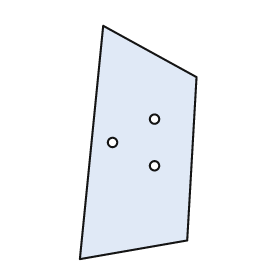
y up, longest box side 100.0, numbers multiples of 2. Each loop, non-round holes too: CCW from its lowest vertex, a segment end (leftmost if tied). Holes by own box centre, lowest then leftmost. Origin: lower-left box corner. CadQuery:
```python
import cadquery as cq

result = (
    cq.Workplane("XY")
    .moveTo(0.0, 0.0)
    .lineTo(46.0, 8.0)
    .lineTo(50.0, 78.0)
    .lineTo(10.0, 100.0)
    .close()
    .moveTo(32.0, 40.0)
    .circle(2.0)
    .moveTo(14.0, 50.0)
    .circle(2.0)
    .moveTo(32.0, 60.0)
    .circle(2.0)
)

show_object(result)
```